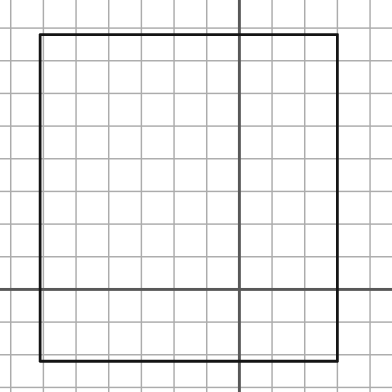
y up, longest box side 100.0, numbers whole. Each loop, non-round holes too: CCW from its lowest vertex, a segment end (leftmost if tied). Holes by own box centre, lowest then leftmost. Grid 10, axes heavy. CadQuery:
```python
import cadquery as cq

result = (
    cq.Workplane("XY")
    .moveTo(-61.0, -22.0)
    .lineTo(30.0, -22.0)
    .lineTo(30.0, 78.0)
    .lineTo(-61.0, 78.0)
    .close()
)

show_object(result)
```